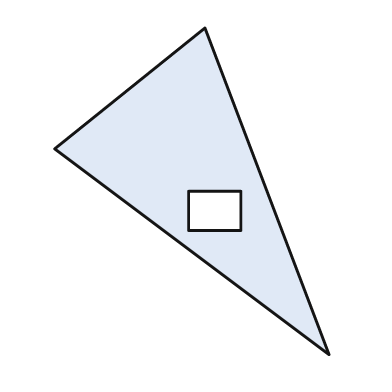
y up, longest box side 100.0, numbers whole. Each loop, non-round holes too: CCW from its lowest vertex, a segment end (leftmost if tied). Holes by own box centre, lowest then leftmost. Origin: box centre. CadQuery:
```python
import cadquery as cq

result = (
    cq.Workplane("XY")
    .moveTo(42.0, -50.0)
    .lineTo(4.0, 50.0)
    .lineTo(-42.0, 13.0)
    .close()
    .moveTo(-1.0, -12.0)
    .lineTo(15.0, -12.0)
    .lineTo(15.0, 0.0)
    .lineTo(-1.0, 0.0)
    .close()
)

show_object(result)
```